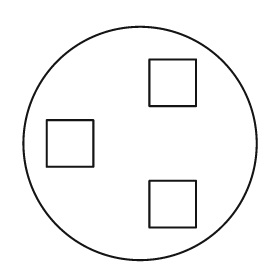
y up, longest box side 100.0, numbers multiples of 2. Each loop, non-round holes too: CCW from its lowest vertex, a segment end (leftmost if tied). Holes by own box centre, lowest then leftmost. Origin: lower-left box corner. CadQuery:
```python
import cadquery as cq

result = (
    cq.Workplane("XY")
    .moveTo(50.0, 50.0)
    .circle(50.0)
    .moveTo(54.0, 14.0)
    .lineTo(74.0, 14.0)
    .lineTo(74.0, 34.0)
    .lineTo(54.0, 34.0)
    .close()
    .moveTo(10.0, 40.0)
    .lineTo(30.0, 40.0)
    .lineTo(30.0, 60.0)
    .lineTo(10.0, 60.0)
    .close()
    .moveTo(54.0, 66.0)
    .lineTo(74.0, 66.0)
    .lineTo(74.0, 86.0)
    .lineTo(54.0, 86.0)
    .close()
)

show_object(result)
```